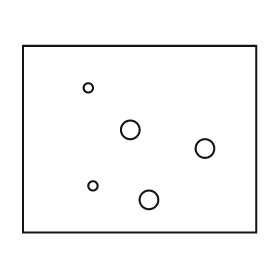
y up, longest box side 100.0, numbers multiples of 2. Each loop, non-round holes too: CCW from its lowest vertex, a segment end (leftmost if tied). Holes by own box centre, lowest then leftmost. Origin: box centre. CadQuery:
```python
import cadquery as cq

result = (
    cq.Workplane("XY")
    .moveTo(-50.0, -40.0)
    .lineTo(50.0, -40.0)
    .lineTo(50.0, 40.0)
    .lineTo(-50.0, 40.0)
    .close()
    .moveTo(4.0, -26.0)
    .circle(4.0)
    .moveTo(-20.0, -20.0)
    .circle(2.0)
    .moveTo(28.0, -4.0)
    .circle(4.0)
    .moveTo(-4.0, 4.0)
    .circle(4.0)
    .moveTo(-22.0, 22.0)
    .circle(2.0)
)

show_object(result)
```